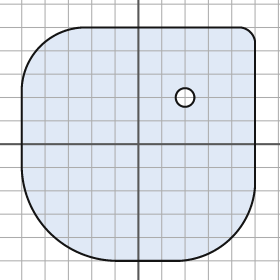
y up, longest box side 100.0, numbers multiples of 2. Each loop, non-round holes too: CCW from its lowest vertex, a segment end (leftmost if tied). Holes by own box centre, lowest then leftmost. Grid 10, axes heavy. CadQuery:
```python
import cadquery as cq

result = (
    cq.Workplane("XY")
    .moveTo(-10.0, -50.0)
    .lineTo(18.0, -50.0)
    .threePointArc((40.0, -40.0), (50.0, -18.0))
    .lineTo(50.0, 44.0)
    .threePointArc((48.0, 48.0), (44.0, 50.0))
    .lineTo(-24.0, 50.0)
    .threePointArc((-42.0, 42.0), (-50.0, 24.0))
    .lineTo(-50.0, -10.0)
    .threePointArc((-38.0, -38.0), (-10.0, -50.0))
    .close()
    .moveTo(20.0, 20.0)
    .circle(4.0)
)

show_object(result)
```